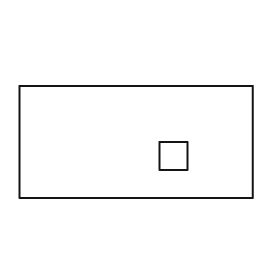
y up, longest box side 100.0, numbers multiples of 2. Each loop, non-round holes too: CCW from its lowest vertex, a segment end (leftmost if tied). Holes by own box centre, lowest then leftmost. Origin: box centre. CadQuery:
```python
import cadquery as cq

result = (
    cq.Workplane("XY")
    .moveTo(-50.0, -24.0)
    .lineTo(50.0, -24.0)
    .lineTo(50.0, 24.0)
    .lineTo(-50.0, 24.0)
    .close()
    .moveTo(10.0, -12.0)
    .lineTo(22.0, -12.0)
    .lineTo(22.0, 0.0)
    .lineTo(10.0, 0.0)
    .close()
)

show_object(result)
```